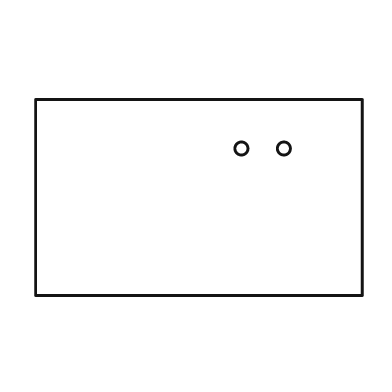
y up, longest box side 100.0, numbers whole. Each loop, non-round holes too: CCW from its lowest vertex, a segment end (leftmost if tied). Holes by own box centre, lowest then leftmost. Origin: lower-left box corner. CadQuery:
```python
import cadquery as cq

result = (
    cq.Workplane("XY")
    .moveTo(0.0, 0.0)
    .lineTo(100.0, 0.0)
    .lineTo(100.0, 60.0)
    .lineTo(0.0, 60.0)
    .close()
    .moveTo(63.0, 45.0)
    .circle(2.0)
    .moveTo(76.0, 45.0)
    .circle(2.0)
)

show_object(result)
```